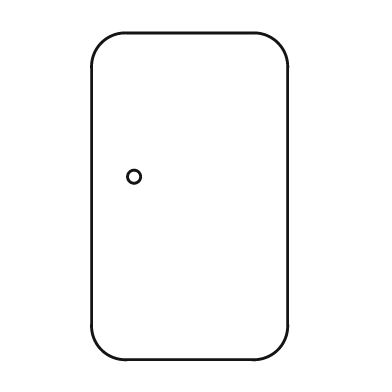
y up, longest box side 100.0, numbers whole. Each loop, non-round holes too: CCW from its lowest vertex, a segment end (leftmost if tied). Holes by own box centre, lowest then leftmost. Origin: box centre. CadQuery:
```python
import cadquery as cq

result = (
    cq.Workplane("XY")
    .moveTo(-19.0, -50.0)
    .lineTo(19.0, -50.0)
    .threePointArc((27.0, -47.0), (30.0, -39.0))
    .lineTo(30.0, 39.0)
    .threePointArc((27.0, 47.0), (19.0, 50.0))
    .lineTo(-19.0, 50.0)
    .threePointArc((-27.0, 47.0), (-30.0, 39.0))
    .lineTo(-30.0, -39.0)
    .threePointArc((-27.0, -47.0), (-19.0, -50.0))
    .close()
    .moveTo(-17.0, 6.0)
    .circle(2.0)
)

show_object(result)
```